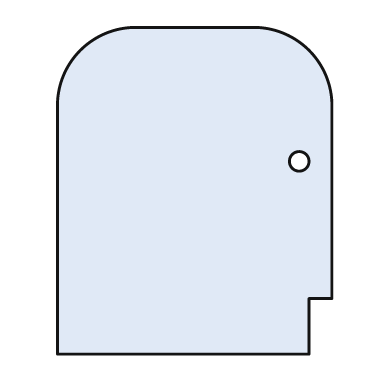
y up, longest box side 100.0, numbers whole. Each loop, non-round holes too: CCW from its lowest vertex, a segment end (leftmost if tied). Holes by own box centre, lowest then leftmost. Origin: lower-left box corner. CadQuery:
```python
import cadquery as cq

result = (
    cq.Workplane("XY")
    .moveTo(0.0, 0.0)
    .lineTo(77.0, 0.0)
    .lineTo(77.0, 17.0)
    .lineTo(84.0, 17.0)
    .lineTo(84.0, 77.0)
    .threePointArc((77.0, 93.0), (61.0, 100.0))
    .lineTo(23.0, 100.0)
    .threePointArc((7.0, 93.0), (0.0, 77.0))
    .close()
    .moveTo(74.0, 59.0)
    .circle(3.0)
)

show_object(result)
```